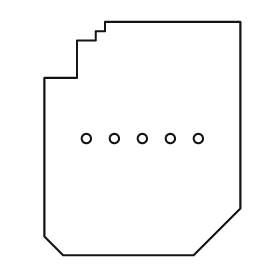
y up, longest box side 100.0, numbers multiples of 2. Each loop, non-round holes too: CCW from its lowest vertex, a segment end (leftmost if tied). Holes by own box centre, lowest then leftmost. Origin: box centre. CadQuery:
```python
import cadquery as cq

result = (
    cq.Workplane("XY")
    .moveTo(-34.0, -50.0)
    .lineTo(22.0, -50.0)
    .lineTo(42.0, -30.0)
    .lineTo(42.0, 50.0)
    .lineTo(-16.0, 50.0)
    .lineTo(-16.0, 46.0)
    .lineTo(-20.0, 46.0)
    .lineTo(-20.0, 42.0)
    .lineTo(-28.0, 42.0)
    .lineTo(-28.0, 26.0)
    .lineTo(-42.0, 26.0)
    .lineTo(-42.0, -42.0)
    .close()
    .moveTo(-24.0, 0.0)
    .circle(2.0)
    .moveTo(-12.0, 0.0)
    .circle(2.0)
    .moveTo(0.0, 0.0)
    .circle(2.0)
    .moveTo(12.0, 0.0)
    .circle(2.0)
    .moveTo(24.0, 0.0)
    .circle(2.0)
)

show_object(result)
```